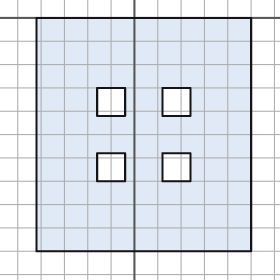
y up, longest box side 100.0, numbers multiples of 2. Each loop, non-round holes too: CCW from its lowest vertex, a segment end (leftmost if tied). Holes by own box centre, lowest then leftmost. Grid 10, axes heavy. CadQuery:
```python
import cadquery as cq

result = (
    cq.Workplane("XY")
    .moveTo(-42.0, -100.0)
    .lineTo(50.0, -100.0)
    .lineTo(50.0, 0.0)
    .lineTo(-42.0, 0.0)
    .close()
    .moveTo(-16.0, -70.0)
    .lineTo(-4.0, -70.0)
    .lineTo(-4.0, -58.0)
    .lineTo(-16.0, -58.0)
    .close()
    .moveTo(12.0, -70.0)
    .lineTo(24.0, -70.0)
    .lineTo(24.0, -58.0)
    .lineTo(12.0, -58.0)
    .close()
    .moveTo(-16.0, -42.0)
    .lineTo(-4.0, -42.0)
    .lineTo(-4.0, -30.0)
    .lineTo(-16.0, -30.0)
    .close()
    .moveTo(12.0, -42.0)
    .lineTo(24.0, -42.0)
    .lineTo(24.0, -30.0)
    .lineTo(12.0, -30.0)
    .close()
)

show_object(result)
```